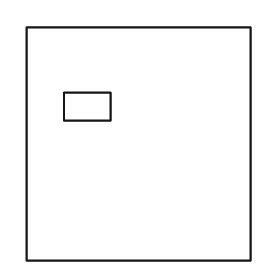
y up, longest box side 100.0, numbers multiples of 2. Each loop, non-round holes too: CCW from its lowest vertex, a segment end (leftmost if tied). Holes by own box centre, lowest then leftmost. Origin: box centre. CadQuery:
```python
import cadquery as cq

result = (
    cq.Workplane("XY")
    .moveTo(-48.0, -50.0)
    .lineTo(48.0, -50.0)
    .lineTo(48.0, 50.0)
    .lineTo(-48.0, 50.0)
    .close()
    .moveTo(-32.0, 10.0)
    .lineTo(-12.0, 10.0)
    .lineTo(-12.0, 22.0)
    .lineTo(-32.0, 22.0)
    .close()
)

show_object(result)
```